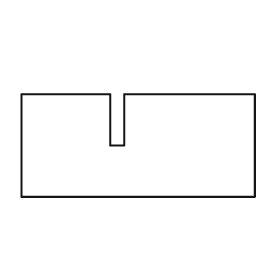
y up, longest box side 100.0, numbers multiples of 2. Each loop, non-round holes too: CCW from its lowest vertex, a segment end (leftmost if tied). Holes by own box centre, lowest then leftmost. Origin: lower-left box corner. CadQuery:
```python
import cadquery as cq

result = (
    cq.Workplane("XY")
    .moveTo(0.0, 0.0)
    .lineTo(100.0, 0.0)
    .lineTo(100.0, 44.0)
    .lineTo(44.0, 44.0)
    .lineTo(44.0, 22.0)
    .lineTo(38.0, 22.0)
    .lineTo(38.0, 44.0)
    .lineTo(0.0, 44.0)
    .close()
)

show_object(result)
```